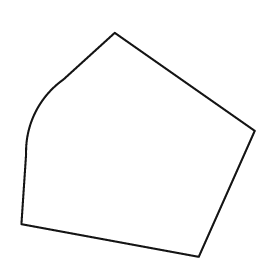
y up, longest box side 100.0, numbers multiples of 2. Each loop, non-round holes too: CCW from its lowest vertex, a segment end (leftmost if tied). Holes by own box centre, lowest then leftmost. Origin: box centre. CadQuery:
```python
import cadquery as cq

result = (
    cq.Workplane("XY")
    .moveTo(26.0, -48.0)
    .lineTo(50.0, 6.0)
    .lineTo(-10.0, 48.0)
    .lineTo(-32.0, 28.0)
    .threePointArc((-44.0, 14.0), (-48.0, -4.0))
    .lineTo(-50.0, -34.0)
    .close()
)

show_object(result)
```